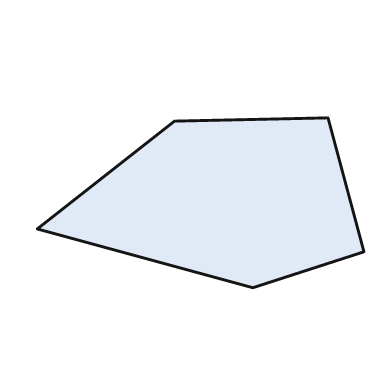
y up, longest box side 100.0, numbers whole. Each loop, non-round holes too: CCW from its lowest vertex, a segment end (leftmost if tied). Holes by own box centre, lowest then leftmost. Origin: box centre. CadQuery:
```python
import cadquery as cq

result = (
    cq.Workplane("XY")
    .moveTo(16.0, -26.0)
    .lineTo(50.0, -15.0)
    .lineTo(39.0, 26.0)
    .lineTo(-8.0, 25.0)
    .lineTo(-50.0, -8.0)
    .close()
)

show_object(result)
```